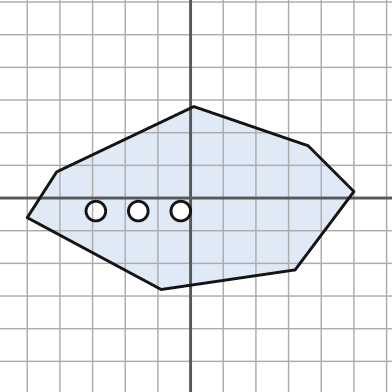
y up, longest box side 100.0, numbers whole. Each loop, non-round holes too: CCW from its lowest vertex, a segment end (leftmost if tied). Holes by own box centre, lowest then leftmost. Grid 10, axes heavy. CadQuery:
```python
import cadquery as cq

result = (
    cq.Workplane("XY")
    .moveTo(-9.0, -28.0)
    .lineTo(32.0, -22.0)
    .lineTo(50.0, 2.0)
    .lineTo(36.0, 16.0)
    .lineTo(1.0, 28.0)
    .lineTo(-41.0, 8.0)
    .lineTo(-50.0, -6.0)
    .close()
    .moveTo(-29.0, -4.0)
    .circle(3.0)
    .moveTo(-16.0, -4.0)
    .circle(3.0)
    .moveTo(-3.0, -4.0)
    .circle(3.0)
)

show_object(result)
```